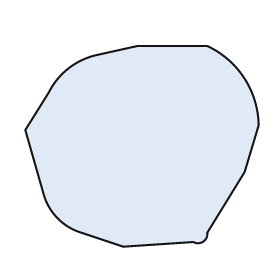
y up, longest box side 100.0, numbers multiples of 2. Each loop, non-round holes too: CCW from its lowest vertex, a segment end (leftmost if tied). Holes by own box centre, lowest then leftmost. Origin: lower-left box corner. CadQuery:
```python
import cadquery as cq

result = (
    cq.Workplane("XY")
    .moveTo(42.0, 0.0)
    .lineTo(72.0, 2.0)
    .threePointArc((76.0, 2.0), (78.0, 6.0))
    .lineTo(94.0, 32.0)
    .lineTo(100.0, 52.0)
    .threePointArc((94.0, 72.0), (78.0, 86.0))
    .lineTo(48.0, 86.0)
    .lineTo(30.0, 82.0)
    .threePointArc((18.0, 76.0), (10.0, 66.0))
    .lineTo(0.0, 50.0)
    .lineTo(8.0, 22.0)
    .threePointArc((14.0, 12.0), (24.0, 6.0))
    .close()
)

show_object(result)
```